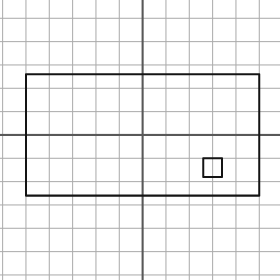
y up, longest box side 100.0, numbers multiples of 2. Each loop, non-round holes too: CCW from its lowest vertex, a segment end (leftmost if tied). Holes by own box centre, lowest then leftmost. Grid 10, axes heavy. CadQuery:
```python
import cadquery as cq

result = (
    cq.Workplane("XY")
    .moveTo(-50.0, -26.0)
    .lineTo(50.0, -26.0)
    .lineTo(50.0, 26.0)
    .lineTo(-50.0, 26.0)
    .close()
    .moveTo(26.0, -18.0)
    .lineTo(34.0, -18.0)
    .lineTo(34.0, -10.0)
    .lineTo(26.0, -10.0)
    .close()
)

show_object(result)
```